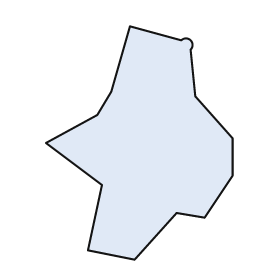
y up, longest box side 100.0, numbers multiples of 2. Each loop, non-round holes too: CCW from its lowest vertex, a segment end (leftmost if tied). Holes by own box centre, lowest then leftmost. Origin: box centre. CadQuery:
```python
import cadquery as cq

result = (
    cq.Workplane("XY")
    .moveTo(-2.0, -50.0)
    .lineTo(16.0, -30.0)
    .lineTo(28.0, -32.0)
    .lineTo(40.0, -14.0)
    .lineTo(40.0, 2.0)
    .lineTo(24.0, 20.0)
    .lineTo(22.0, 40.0)
    .threePointArc((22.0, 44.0), (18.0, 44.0))
    .lineTo(-4.0, 50.0)
    .lineTo(-12.0, 22.0)
    .lineTo(-18.0, 12.0)
    .lineTo(-40.0, 0.0)
    .lineTo(-16.0, -18.0)
    .lineTo(-22.0, -46.0)
    .close()
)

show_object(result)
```